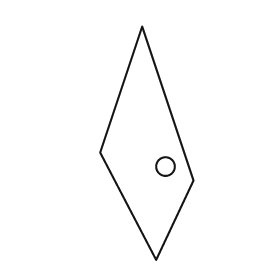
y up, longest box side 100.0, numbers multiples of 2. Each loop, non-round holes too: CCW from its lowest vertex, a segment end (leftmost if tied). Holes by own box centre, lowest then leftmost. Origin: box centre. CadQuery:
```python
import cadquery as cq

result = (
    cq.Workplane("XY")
    .moveTo(4.0, -50.0)
    .lineTo(20.0, -16.0)
    .lineTo(-2.0, 50.0)
    .lineTo(-20.0, -4.0)
    .close()
    .moveTo(8.0, -10.0)
    .circle(4.0)
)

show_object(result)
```